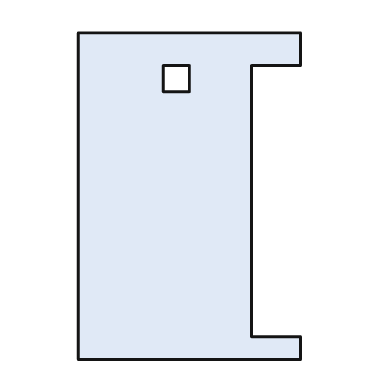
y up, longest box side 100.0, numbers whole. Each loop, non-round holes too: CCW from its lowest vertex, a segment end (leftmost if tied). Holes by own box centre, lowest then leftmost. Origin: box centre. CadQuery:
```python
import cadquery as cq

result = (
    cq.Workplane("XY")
    .moveTo(-34.0, -50.0)
    .lineTo(34.0, -50.0)
    .lineTo(34.0, -43.0)
    .lineTo(19.0, -43.0)
    .lineTo(19.0, 40.0)
    .lineTo(34.0, 40.0)
    .lineTo(34.0, 50.0)
    .lineTo(-34.0, 50.0)
    .close()
    .moveTo(-8.0, 32.0)
    .lineTo(0.0, 32.0)
    .lineTo(0.0, 40.0)
    .lineTo(-8.0, 40.0)
    .close()
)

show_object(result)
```